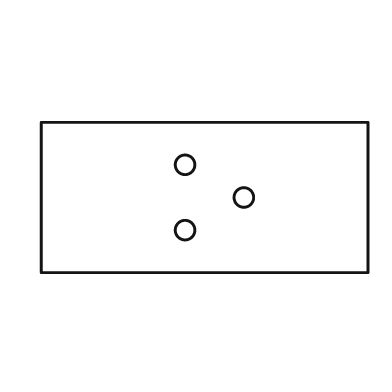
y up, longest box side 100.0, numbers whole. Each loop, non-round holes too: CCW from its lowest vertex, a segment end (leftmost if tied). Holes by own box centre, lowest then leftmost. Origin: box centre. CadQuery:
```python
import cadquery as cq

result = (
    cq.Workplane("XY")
    .moveTo(-50.0, -23.0)
    .lineTo(50.0, -23.0)
    .lineTo(50.0, 23.0)
    .lineTo(-50.0, 23.0)
    .close()
    .moveTo(-6.0, -10.0)
    .circle(3.0)
    .moveTo(12.0, 0.0)
    .circle(3.0)
    .moveTo(-6.0, 10.0)
    .circle(3.0)
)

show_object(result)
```